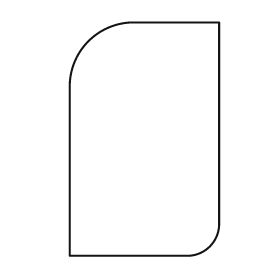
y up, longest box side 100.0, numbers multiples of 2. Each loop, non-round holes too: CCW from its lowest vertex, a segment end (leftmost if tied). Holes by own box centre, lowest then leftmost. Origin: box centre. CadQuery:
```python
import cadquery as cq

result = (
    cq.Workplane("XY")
    .moveTo(-32.0, -50.0)
    .lineTo(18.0, -50.0)
    .threePointArc((28.0, -46.0), (32.0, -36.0))
    .lineTo(32.0, 50.0)
    .lineTo(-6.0, 50.0)
    .threePointArc((-24.0, 42.0), (-32.0, 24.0))
    .close()
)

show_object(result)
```